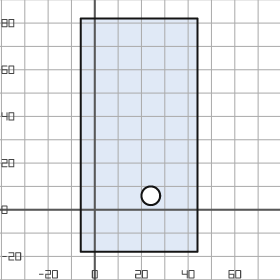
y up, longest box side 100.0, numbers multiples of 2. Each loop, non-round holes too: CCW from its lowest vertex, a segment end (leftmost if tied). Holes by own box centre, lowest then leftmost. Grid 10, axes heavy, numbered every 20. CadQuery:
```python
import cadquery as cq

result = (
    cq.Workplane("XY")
    .moveTo(-6.0, -18.0)
    .lineTo(44.0, -18.0)
    .lineTo(44.0, 82.0)
    .lineTo(-6.0, 82.0)
    .close()
    .moveTo(24.0, 6.0)
    .circle(4.0)
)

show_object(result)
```